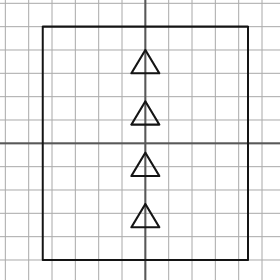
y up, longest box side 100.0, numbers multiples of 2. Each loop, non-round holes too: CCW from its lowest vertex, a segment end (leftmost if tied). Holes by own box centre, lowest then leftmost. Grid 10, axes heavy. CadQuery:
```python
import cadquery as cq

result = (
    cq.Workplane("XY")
    .moveTo(-44.0, -50.0)
    .lineTo(44.0, -50.0)
    .lineTo(44.0, 50.0)
    .lineTo(-44.0, 50.0)
    .close()
    .moveTo(-6.0, -36.0)
    .lineTo(6.0, -36.0)
    .lineTo(0.0, -26.0)
    .close()
    .moveTo(-6.0, -14.0)
    .lineTo(6.0, -14.0)
    .lineTo(0.0, -4.0)
    .close()
    .moveTo(-6.0, 8.0)
    .lineTo(6.0, 8.0)
    .lineTo(0.0, 18.0)
    .close()
    .moveTo(-6.0, 30.0)
    .lineTo(6.0, 30.0)
    .lineTo(0.0, 40.0)
    .close()
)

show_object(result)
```